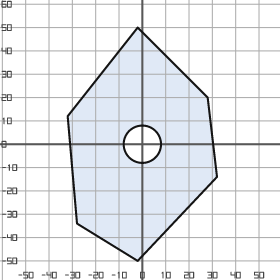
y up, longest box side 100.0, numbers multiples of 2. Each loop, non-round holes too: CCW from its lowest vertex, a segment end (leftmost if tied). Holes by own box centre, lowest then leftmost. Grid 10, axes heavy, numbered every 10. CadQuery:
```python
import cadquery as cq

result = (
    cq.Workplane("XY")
    .moveTo(-2.0, -50.0)
    .lineTo(32.0, -14.0)
    .lineTo(28.0, 20.0)
    .lineTo(-2.0, 50.0)
    .lineTo(-32.0, 12.0)
    .lineTo(-28.0, -34.0)
    .close()
    .moveTo(0.0, 0.0)
    .circle(8.0)
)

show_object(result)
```